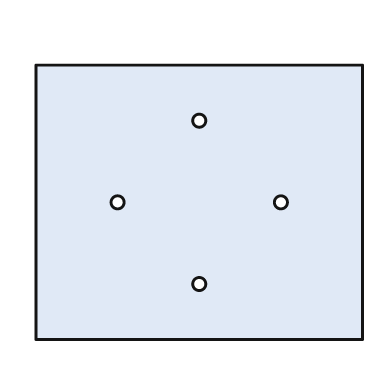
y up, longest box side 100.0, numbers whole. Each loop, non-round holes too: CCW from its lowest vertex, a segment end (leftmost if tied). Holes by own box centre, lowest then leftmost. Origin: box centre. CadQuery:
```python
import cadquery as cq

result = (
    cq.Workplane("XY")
    .moveTo(-50.0, -42.0)
    .lineTo(50.0, -42.0)
    .lineTo(50.0, 42.0)
    .lineTo(-50.0, 42.0)
    .close()
    .moveTo(0.0, -25.0)
    .circle(2.0)
    .moveTo(-25.0, 0.0)
    .circle(2.0)
    .moveTo(25.0, 0.0)
    .circle(2.0)
    .moveTo(0.0, 25.0)
    .circle(2.0)
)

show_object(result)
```